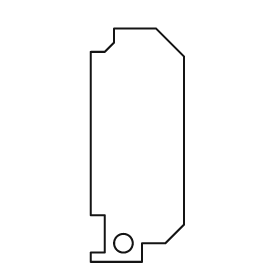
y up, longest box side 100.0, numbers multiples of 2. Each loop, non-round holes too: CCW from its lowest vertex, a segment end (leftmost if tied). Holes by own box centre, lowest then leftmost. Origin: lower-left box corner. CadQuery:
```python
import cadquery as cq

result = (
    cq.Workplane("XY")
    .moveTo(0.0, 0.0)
    .lineTo(22.0, 0.0)
    .lineTo(22.0, 8.0)
    .lineTo(32.0, 8.0)
    .lineTo(40.0, 16.0)
    .lineTo(40.0, 88.0)
    .lineTo(28.0, 100.0)
    .lineTo(10.0, 100.0)
    .lineTo(10.0, 94.0)
    .lineTo(6.0, 90.0)
    .lineTo(0.0, 90.0)
    .lineTo(0.0, 20.0)
    .lineTo(6.0, 20.0)
    .lineTo(6.0, 4.0)
    .lineTo(0.0, 4.0)
    .close()
    .moveTo(14.0, 8.0)
    .circle(4.0)
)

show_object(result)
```